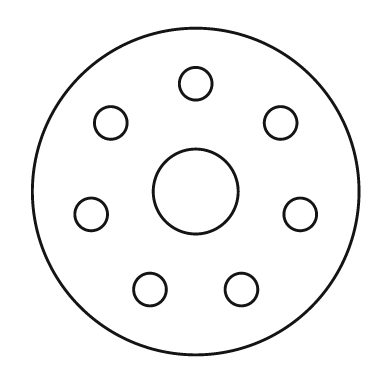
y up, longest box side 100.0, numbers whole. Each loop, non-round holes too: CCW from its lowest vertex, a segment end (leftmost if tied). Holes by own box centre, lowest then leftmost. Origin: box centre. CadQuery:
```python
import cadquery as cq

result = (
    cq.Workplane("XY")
    .moveTo(0.0, 0.0)
    .circle(50.0)
    .moveTo(-14.0, -30.0)
    .circle(5.0)
    .moveTo(14.0, -30.0)
    .circle(5.0)
    .moveTo(-32.0, -7.0)
    .circle(5.0)
    .moveTo(32.0, -7.0)
    .circle(5.0)
    .moveTo(0.0, 0.0)
    .circle(13.0)
    .moveTo(-26.0, 21.0)
    .circle(5.0)
    .moveTo(26.0, 21.0)
    .circle(5.0)
    .moveTo(0.0, 33.0)
    .circle(5.0)
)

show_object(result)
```